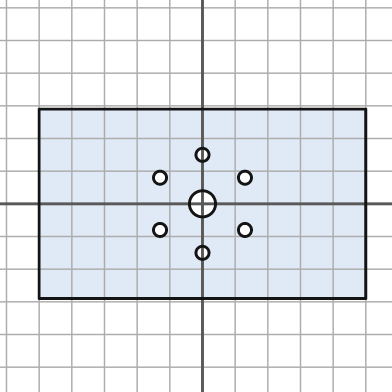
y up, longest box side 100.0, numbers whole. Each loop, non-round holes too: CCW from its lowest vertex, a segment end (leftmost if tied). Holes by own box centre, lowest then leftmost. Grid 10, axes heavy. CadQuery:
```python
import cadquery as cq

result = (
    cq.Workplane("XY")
    .moveTo(-50.0, -29.0)
    .lineTo(50.0, -29.0)
    .lineTo(50.0, 29.0)
    .lineTo(-50.0, 29.0)
    .close()
    .moveTo(0.0, -15.0)
    .circle(2.0)
    .moveTo(-13.0, -8.0)
    .circle(2.0)
    .moveTo(13.0, -8.0)
    .circle(2.0)
    .moveTo(0.0, 0.0)
    .circle(4.0)
    .moveTo(-13.0, 8.0)
    .circle(2.0)
    .moveTo(13.0, 8.0)
    .circle(2.0)
    .moveTo(0.0, 15.0)
    .circle(2.0)
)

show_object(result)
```